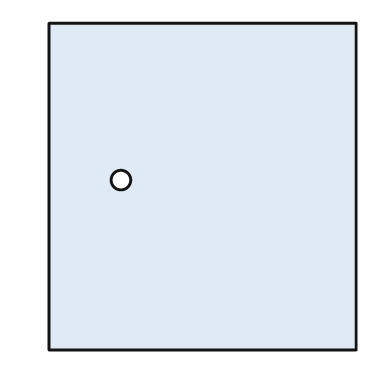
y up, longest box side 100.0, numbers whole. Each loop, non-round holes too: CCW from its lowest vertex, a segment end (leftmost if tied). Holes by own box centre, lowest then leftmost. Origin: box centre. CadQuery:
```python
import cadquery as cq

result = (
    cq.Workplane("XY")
    .moveTo(-47.0, -50.0)
    .lineTo(47.0, -50.0)
    .lineTo(47.0, 50.0)
    .lineTo(-47.0, 50.0)
    .close()
    .moveTo(-25.0, 2.0)
    .circle(3.0)
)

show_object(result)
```